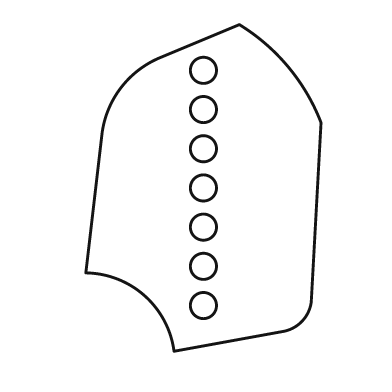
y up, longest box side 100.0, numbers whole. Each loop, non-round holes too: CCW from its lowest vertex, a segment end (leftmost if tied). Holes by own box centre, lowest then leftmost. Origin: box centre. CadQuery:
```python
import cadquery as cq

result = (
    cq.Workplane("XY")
    .moveTo(-9.0, -50.0)
    .lineTo(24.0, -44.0)
    .threePointArc((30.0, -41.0), (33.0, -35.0))
    .lineTo(36.0, 20.0)
    .threePointArc((26.0, 37.0), (11.0, 50.0))
    .lineTo(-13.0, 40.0)
    .threePointArc((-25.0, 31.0), (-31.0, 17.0))
    .lineTo(-36.0, -26.0)
    .threePointArc((-18.0, -33.0), (-9.0, -50.0))
    .close()
    .moveTo(0.0, -36.0)
    .circle(4.0)
    .moveTo(0.0, -24.0)
    .circle(4.0)
    .moveTo(0.0, -12.0)
    .circle(4.0)
    .moveTo(0.0, 0.0)
    .circle(4.0)
    .moveTo(0.0, 12.0)
    .circle(4.0)
    .moveTo(0.0, 24.0)
    .circle(4.0)
    .moveTo(0.0, 36.0)
    .circle(4.0)
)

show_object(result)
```